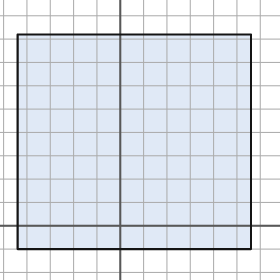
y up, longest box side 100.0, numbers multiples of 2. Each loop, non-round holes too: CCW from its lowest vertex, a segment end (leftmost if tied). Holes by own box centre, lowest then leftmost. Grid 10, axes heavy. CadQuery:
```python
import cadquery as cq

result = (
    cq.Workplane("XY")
    .moveTo(-44.0, -10.0)
    .lineTo(56.0, -10.0)
    .lineTo(56.0, 82.0)
    .lineTo(-44.0, 82.0)
    .close()
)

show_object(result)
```